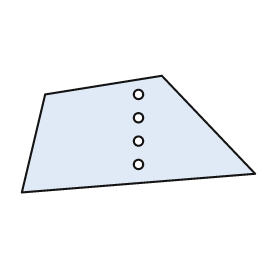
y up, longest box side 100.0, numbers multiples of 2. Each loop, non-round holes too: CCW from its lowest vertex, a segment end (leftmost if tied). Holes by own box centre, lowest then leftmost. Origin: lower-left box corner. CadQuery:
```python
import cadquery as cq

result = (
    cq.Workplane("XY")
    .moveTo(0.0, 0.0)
    .lineTo(100.0, 8.0)
    .lineTo(60.0, 50.0)
    .lineTo(10.0, 42.0)
    .close()
    .moveTo(50.0, 12.0)
    .circle(2.0)
    .moveTo(50.0, 22.0)
    .circle(2.0)
    .moveTo(50.0, 32.0)
    .circle(2.0)
    .moveTo(50.0, 42.0)
    .circle(2.0)
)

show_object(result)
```